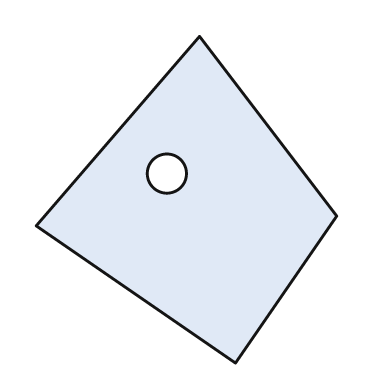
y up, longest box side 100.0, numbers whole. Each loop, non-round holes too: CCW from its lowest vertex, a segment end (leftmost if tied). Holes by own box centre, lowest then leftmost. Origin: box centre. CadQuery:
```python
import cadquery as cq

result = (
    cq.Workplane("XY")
    .moveTo(15.0, -50.0)
    .lineTo(46.0, -5.0)
    .lineTo(4.0, 50.0)
    .lineTo(-46.0, -8.0)
    .close()
    .moveTo(-6.0, 8.0)
    .circle(6.0)
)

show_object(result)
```